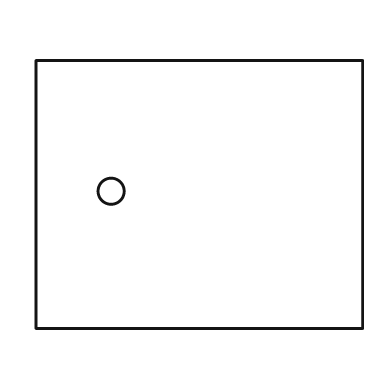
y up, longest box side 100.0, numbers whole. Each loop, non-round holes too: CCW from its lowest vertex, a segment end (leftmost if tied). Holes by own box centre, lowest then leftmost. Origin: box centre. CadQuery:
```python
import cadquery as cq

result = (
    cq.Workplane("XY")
    .moveTo(-50.0, -41.0)
    .lineTo(50.0, -41.0)
    .lineTo(50.0, 41.0)
    .lineTo(-50.0, 41.0)
    .close()
    .moveTo(-27.0, 1.0)
    .circle(4.0)
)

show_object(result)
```